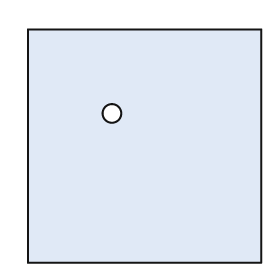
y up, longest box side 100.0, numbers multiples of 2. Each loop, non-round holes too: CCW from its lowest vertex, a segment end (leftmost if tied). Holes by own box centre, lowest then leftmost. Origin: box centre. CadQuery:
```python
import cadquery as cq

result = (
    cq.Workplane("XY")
    .moveTo(-50.0, -50.0)
    .lineTo(50.0, -50.0)
    .lineTo(50.0, 50.0)
    .lineTo(-50.0, 50.0)
    .close()
    .moveTo(-14.0, 14.0)
    .circle(4.0)
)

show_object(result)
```